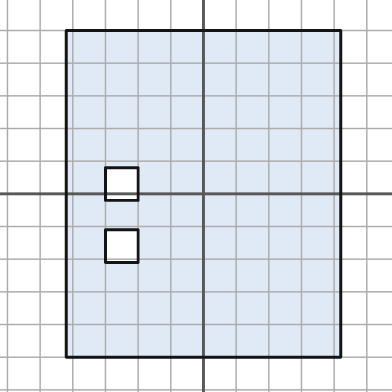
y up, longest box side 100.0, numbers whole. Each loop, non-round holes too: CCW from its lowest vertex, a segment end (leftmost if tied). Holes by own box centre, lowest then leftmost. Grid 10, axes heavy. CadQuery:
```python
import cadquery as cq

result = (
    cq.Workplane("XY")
    .moveTo(-42.0, -50.0)
    .lineTo(42.0, -50.0)
    .lineTo(42.0, 50.0)
    .lineTo(-42.0, 50.0)
    .close()
    .moveTo(-30.0, -21.0)
    .lineTo(-20.0, -21.0)
    .lineTo(-20.0, -11.0)
    .lineTo(-30.0, -11.0)
    .close()
    .moveTo(-30.0, -2.0)
    .lineTo(-20.0, -2.0)
    .lineTo(-20.0, 8.0)
    .lineTo(-30.0, 8.0)
    .close()
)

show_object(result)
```